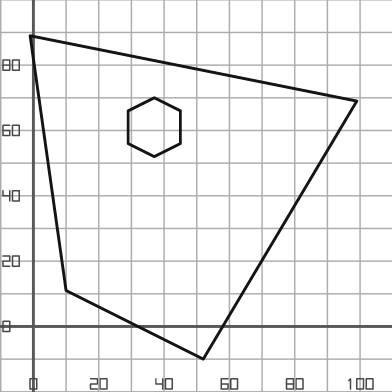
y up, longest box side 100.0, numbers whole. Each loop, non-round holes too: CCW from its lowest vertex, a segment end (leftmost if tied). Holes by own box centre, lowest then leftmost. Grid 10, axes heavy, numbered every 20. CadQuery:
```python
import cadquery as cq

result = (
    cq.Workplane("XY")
    .moveTo(52.0, -10.0)
    .lineTo(99.0, 69.0)
    .lineTo(-1.0, 89.0)
    .lineTo(10.0, 11.0)
    .close()
    .moveTo(37.0, 52.0)
    .lineTo(45.0, 56.0)
    .lineTo(45.0, 66.0)
    .lineTo(37.0, 70.0)
    .lineTo(29.0, 66.0)
    .lineTo(29.0, 56.0)
    .close()
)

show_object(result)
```